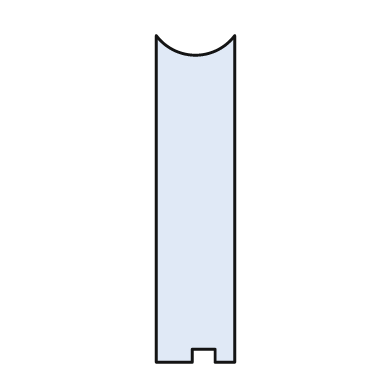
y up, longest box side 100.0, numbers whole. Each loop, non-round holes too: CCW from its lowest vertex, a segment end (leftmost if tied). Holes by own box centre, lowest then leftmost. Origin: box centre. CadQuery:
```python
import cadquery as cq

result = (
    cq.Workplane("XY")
    .moveTo(-12.0, -50.0)
    .lineTo(-1.0, -50.0)
    .lineTo(-1.0, -46.0)
    .lineTo(6.0, -46.0)
    .lineTo(6.0, -50.0)
    .lineTo(12.0, -50.0)
    .lineTo(12.0, 50.0)
    .threePointArc((0.0, 44.0), (-12.0, 50.0))
    .close()
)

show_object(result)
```